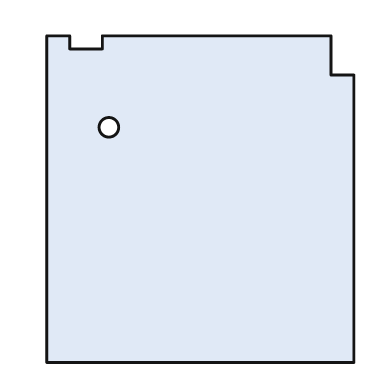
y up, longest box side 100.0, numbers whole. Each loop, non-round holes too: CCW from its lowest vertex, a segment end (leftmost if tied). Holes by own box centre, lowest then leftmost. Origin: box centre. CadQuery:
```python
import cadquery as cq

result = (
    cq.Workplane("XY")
    .moveTo(-47.0, -50.0)
    .lineTo(47.0, -50.0)
    .lineTo(47.0, 38.0)
    .lineTo(40.0, 38.0)
    .lineTo(40.0, 50.0)
    .lineTo(-30.0, 50.0)
    .lineTo(-30.0, 46.0)
    .lineTo(-40.0, 46.0)
    .lineTo(-40.0, 50.0)
    .lineTo(-47.0, 50.0)
    .close()
    .moveTo(-28.0, 22.0)
    .circle(3.0)
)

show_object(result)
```